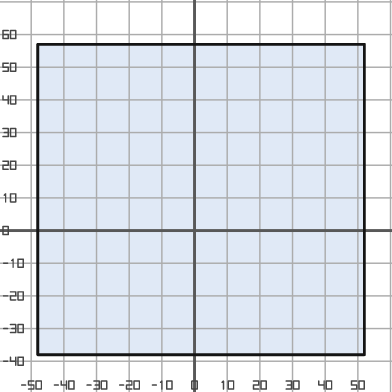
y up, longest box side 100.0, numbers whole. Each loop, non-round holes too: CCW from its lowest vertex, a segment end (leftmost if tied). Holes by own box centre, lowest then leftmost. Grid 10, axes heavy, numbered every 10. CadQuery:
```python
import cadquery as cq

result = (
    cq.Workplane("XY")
    .moveTo(-48.0, -38.0)
    .lineTo(52.0, -38.0)
    .lineTo(52.0, 57.0)
    .lineTo(-48.0, 57.0)
    .close()
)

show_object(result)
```